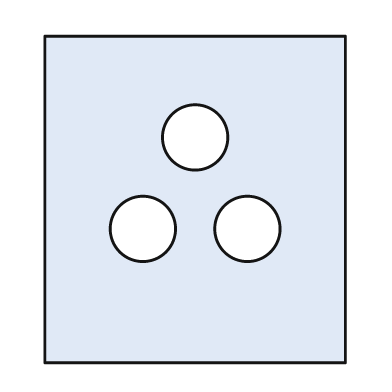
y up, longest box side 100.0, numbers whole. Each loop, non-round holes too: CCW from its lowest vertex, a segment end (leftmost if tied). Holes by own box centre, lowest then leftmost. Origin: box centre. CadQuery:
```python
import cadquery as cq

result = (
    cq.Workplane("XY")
    .moveTo(-46.0, -50.0)
    .lineTo(46.0, -50.0)
    .lineTo(46.0, 50.0)
    .lineTo(-46.0, 50.0)
    .close()
    .moveTo(-16.0, -9.0)
    .circle(10.0)
    .moveTo(16.0, -9.0)
    .circle(10.0)
    .moveTo(0.0, 19.0)
    .circle(10.0)
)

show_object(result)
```